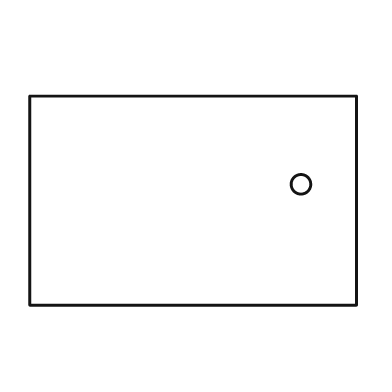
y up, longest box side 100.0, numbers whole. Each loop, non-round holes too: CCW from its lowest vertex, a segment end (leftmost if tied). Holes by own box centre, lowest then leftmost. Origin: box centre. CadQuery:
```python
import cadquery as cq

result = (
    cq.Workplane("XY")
    .moveTo(-50.0, -32.0)
    .lineTo(50.0, -32.0)
    .lineTo(50.0, 32.0)
    .lineTo(-50.0, 32.0)
    .close()
    .moveTo(33.0, 5.0)
    .circle(3.0)
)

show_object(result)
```